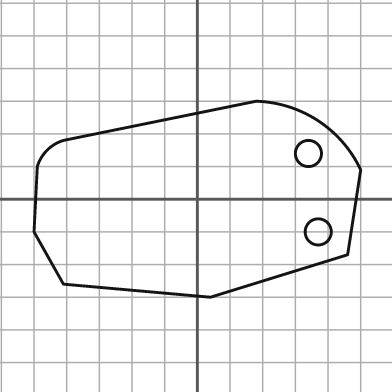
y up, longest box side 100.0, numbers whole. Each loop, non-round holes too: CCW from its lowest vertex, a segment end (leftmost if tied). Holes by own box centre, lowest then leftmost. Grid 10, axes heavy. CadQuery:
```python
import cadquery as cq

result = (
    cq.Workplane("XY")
    .moveTo(4.0, -30.0)
    .lineTo(46.0, -17.0)
    .lineTo(50.0, 9.0)
    .threePointArc((37.0, 24.0), (18.0, 30.0))
    .lineTo(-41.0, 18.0)
    .threePointArc((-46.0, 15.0), (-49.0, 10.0))
    .lineTo(-50.0, -10.0)
    .lineTo(-41.0, -26.0)
    .close()
    .moveTo(37.0, -10.0)
    .circle(4.0)
    .moveTo(34.0, 14.0)
    .circle(4.0)
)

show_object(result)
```